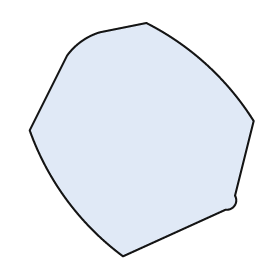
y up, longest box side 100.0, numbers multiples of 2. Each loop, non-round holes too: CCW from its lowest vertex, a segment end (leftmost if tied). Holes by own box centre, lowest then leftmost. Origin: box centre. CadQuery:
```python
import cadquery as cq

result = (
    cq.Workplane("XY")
    .moveTo(-8.0, -50.0)
    .lineTo(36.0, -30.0)
    .threePointArc((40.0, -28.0), (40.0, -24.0))
    .lineTo(48.0, 8.0)
    .threePointArc((28.0, 32.0), (2.0, 50.0))
    .lineTo(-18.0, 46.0)
    .threePointArc((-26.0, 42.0), (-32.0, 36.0))
    .lineTo(-48.0, 4.0)
    .threePointArc((-32.0, -26.0), (-8.0, -50.0))
    .close()
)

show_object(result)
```